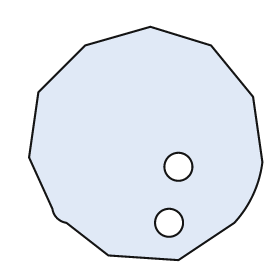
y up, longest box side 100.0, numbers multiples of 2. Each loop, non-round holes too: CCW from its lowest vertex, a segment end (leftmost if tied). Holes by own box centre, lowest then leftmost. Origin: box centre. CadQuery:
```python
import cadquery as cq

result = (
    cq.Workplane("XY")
    .moveTo(14.0, -50.0)
    .lineTo(38.0, -34.0)
    .threePointArc((46.0, -22.0), (50.0, -8.0))
    .lineTo(46.0, 20.0)
    .lineTo(28.0, 42.0)
    .lineTo(2.0, 50.0)
    .lineTo(-26.0, 42.0)
    .lineTo(-46.0, 22.0)
    .lineTo(-50.0, -6.0)
    .lineTo(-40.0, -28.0)
    .threePointArc((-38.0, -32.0), (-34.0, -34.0))
    .lineTo(-16.0, -48.0)
    .close()
    .moveTo(10.0, -34.0)
    .circle(6.0)
    .moveTo(14.0, -10.0)
    .circle(6.0)
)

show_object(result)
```